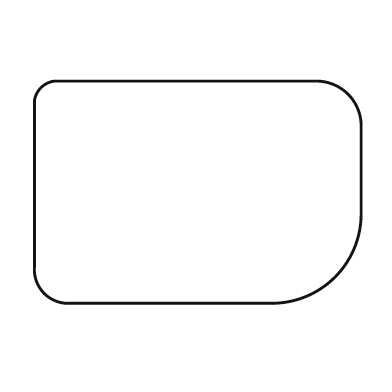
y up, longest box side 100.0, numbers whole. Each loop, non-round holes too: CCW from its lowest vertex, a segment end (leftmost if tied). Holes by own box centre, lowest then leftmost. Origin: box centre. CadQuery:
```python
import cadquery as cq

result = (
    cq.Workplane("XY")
    .moveTo(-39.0, -34.0)
    .lineTo(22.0, -34.0)
    .threePointArc((42.0, -26.0), (50.0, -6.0))
    .lineTo(50.0, 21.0)
    .threePointArc((46.0, 30.0), (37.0, 34.0))
    .lineTo(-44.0, 34.0)
    .threePointArc((-48.0, 32.0), (-50.0, 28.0))
    .lineTo(-50.0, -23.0)
    .threePointArc((-47.0, -31.0), (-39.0, -34.0))
    .close()
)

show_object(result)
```